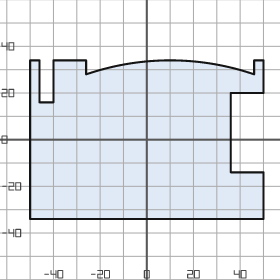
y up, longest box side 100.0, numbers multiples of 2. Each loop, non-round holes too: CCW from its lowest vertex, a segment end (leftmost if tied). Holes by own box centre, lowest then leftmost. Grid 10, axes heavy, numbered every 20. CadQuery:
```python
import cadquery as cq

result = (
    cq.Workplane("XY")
    .moveTo(-50.0, -34.0)
    .lineTo(50.0, -34.0)
    .lineTo(50.0, -14.0)
    .lineTo(36.0, -14.0)
    .lineTo(36.0, 20.0)
    .lineTo(50.0, 20.0)
    .lineTo(50.0, 34.0)
    .lineTo(46.0, 34.0)
    .lineTo(46.0, 28.0)
    .threePointArc((10.0, 34.0), (-26.0, 28.0))
    .lineTo(-26.0, 34.0)
    .lineTo(-40.0, 34.0)
    .lineTo(-40.0, 16.0)
    .lineTo(-46.0, 16.0)
    .lineTo(-46.0, 34.0)
    .lineTo(-50.0, 34.0)
    .close()
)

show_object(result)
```